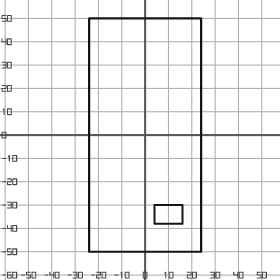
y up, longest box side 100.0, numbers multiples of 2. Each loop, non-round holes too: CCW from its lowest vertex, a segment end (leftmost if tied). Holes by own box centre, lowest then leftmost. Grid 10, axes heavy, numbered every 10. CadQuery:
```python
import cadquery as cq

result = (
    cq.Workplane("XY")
    .moveTo(-24.0, -50.0)
    .lineTo(24.0, -50.0)
    .lineTo(24.0, 50.0)
    .lineTo(-24.0, 50.0)
    .close()
    .moveTo(4.0, -38.0)
    .lineTo(16.0, -38.0)
    .lineTo(16.0, -30.0)
    .lineTo(4.0, -30.0)
    .close()
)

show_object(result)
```